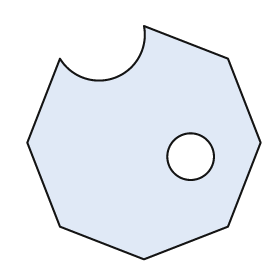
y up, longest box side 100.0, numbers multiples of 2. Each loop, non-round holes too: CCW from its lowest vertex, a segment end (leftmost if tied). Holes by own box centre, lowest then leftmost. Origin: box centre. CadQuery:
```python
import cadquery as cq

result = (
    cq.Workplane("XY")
    .moveTo(0.0, -50.0)
    .lineTo(36.0, -36.0)
    .lineTo(50.0, 0.0)
    .lineTo(36.0, 36.0)
    .lineTo(0.0, 50.0)
    .threePointArc((-12.0, 28.0), (-36.0, 36.0))
    .lineTo(-50.0, 0.0)
    .lineTo(-36.0, -36.0)
    .close()
    .moveTo(20.0, -6.0)
    .circle(10.0)
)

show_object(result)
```